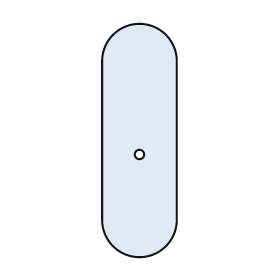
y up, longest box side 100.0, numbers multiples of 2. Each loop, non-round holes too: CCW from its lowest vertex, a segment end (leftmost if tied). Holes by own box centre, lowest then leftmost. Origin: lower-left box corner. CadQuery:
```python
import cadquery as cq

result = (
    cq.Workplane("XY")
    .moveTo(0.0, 16.0)
    .threePointArc((16.0, 0.0), (32.0, 16.0))
    .lineTo(32.0, 84.0)
    .threePointArc((16.0, 100.0), (0.0, 84.0))
    .close()
    .moveTo(16.0, 44.0)
    .circle(2.0)
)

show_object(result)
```